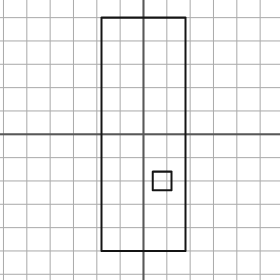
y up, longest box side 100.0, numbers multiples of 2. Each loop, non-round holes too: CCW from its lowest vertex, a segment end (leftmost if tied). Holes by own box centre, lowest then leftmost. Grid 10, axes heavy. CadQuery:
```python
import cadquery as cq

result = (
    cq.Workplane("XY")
    .moveTo(-18.0, -50.0)
    .lineTo(18.0, -50.0)
    .lineTo(18.0, 50.0)
    .lineTo(-18.0, 50.0)
    .close()
    .moveTo(4.0, -24.0)
    .lineTo(12.0, -24.0)
    .lineTo(12.0, -16.0)
    .lineTo(4.0, -16.0)
    .close()
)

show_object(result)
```